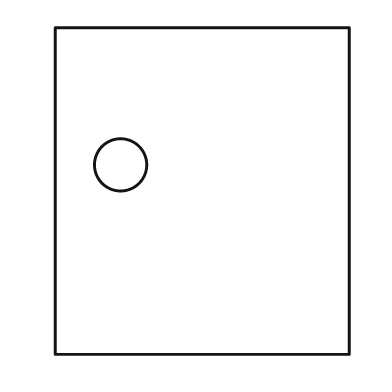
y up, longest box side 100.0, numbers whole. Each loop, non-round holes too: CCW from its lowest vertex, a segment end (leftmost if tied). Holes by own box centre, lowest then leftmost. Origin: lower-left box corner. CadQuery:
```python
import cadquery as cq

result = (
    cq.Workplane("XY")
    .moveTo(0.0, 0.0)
    .lineTo(90.0, 0.0)
    .lineTo(90.0, 100.0)
    .lineTo(0.0, 100.0)
    .close()
    .moveTo(20.0, 58.0)
    .circle(8.0)
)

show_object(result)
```